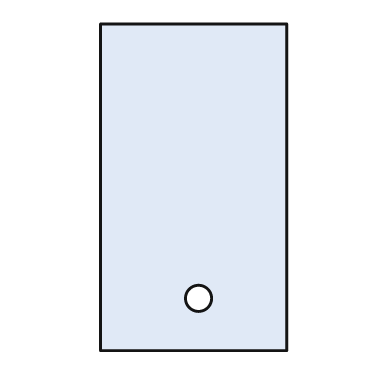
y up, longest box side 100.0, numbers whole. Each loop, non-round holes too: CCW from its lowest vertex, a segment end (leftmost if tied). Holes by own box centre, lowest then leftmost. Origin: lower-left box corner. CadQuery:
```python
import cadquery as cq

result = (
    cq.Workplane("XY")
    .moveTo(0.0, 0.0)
    .lineTo(57.0, 0.0)
    .lineTo(57.0, 100.0)
    .lineTo(0.0, 100.0)
    .close()
    .moveTo(30.0, 16.0)
    .circle(4.0)
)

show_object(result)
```